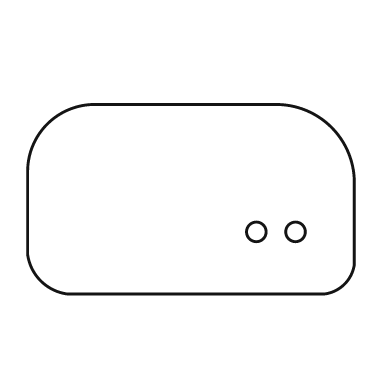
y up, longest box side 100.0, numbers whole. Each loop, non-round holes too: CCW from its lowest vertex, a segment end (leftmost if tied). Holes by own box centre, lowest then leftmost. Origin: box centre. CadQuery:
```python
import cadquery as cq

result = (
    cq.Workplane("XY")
    .moveTo(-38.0, -29.0)
    .lineTo(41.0, -29.0)
    .threePointArc((47.0, -26.0), (50.0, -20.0))
    .lineTo(50.0, 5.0)
    .threePointArc((43.0, 22.0), (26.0, 29.0))
    .lineTo(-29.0, 29.0)
    .threePointArc((-44.0, 23.0), (-50.0, 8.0))
    .lineTo(-50.0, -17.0)
    .threePointArc((-46.0, -25.0), (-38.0, -29.0))
    .close()
    .moveTo(20.0, -10.0)
    .circle(3.0)
    .moveTo(32.0, -10.0)
    .circle(3.0)
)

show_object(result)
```